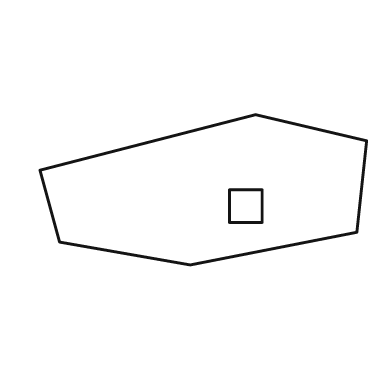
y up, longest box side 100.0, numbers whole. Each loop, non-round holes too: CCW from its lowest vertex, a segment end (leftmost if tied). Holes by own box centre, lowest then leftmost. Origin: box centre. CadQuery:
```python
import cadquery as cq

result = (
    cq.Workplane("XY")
    .moveTo(-4.0, -23.0)
    .lineTo(47.0, -13.0)
    .lineTo(50.0, 15.0)
    .lineTo(16.0, 23.0)
    .lineTo(-50.0, 6.0)
    .lineTo(-44.0, -16.0)
    .close()
    .moveTo(8.0, -10.0)
    .lineTo(18.0, -10.0)
    .lineTo(18.0, 0.0)
    .lineTo(8.0, 0.0)
    .close()
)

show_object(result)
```